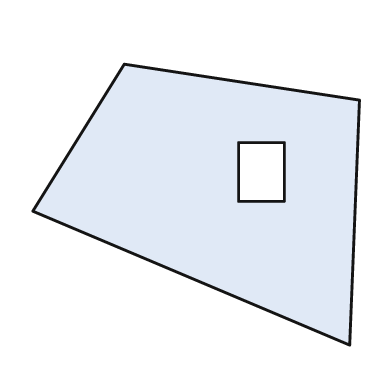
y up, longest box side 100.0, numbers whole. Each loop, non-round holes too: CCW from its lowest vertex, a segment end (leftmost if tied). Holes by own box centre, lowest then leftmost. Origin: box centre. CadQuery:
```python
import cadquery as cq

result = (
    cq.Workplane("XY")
    .moveTo(47.0, -43.0)
    .lineTo(50.0, 32.0)
    .lineTo(-22.0, 43.0)
    .lineTo(-50.0, -2.0)
    .close()
    .moveTo(13.0, 1.0)
    .lineTo(27.0, 1.0)
    .lineTo(27.0, 19.0)
    .lineTo(13.0, 19.0)
    .close()
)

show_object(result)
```